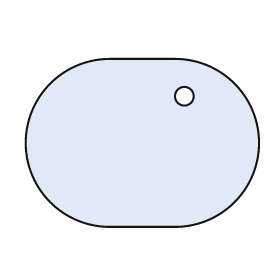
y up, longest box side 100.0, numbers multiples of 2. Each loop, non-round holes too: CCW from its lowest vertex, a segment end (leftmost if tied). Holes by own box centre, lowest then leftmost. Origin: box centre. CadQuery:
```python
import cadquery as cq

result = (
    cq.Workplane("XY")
    .moveTo(-14.0, -36.0)
    .lineTo(14.0, -36.0)
    .threePointArc((50.0, 0.0), (14.0, 36.0))
    .lineTo(-14.0, 36.0)
    .threePointArc((-50.0, 0.0), (-14.0, -36.0))
    .close()
    .moveTo(18.0, 20.0)
    .circle(4.0)
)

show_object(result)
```